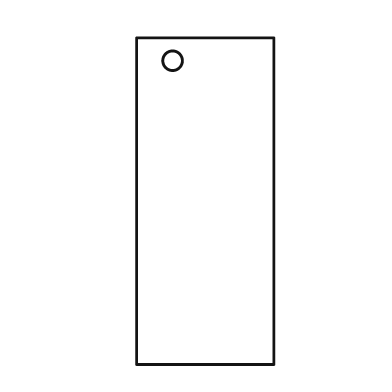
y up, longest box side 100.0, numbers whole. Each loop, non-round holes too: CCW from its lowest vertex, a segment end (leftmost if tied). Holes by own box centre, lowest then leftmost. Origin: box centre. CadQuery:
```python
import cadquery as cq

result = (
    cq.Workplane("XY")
    .moveTo(-21.0, -50.0)
    .lineTo(21.0, -50.0)
    .lineTo(21.0, 50.0)
    .lineTo(-21.0, 50.0)
    .close()
    .moveTo(-10.0, 43.0)
    .circle(3.0)
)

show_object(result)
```